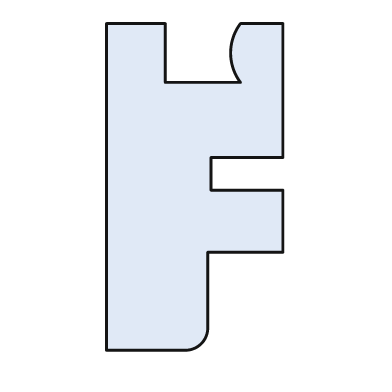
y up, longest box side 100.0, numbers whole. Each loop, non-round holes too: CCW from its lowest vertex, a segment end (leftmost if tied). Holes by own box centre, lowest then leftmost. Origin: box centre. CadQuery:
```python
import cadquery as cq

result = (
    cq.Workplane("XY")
    .moveTo(-27.0, -50.0)
    .lineTo(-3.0, -50.0)
    .threePointArc((2.0, -48.0), (4.0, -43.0))
    .lineTo(4.0, -20.0)
    .lineTo(27.0, -20.0)
    .lineTo(27.0, -1.0)
    .lineTo(5.0, -1.0)
    .lineTo(5.0, 9.0)
    .lineTo(27.0, 9.0)
    .lineTo(27.0, 50.0)
    .lineTo(14.0, 50.0)
    .threePointArc((11.0, 41.0), (14.0, 32.0))
    .lineTo(-9.0, 32.0)
    .lineTo(-9.0, 50.0)
    .lineTo(-27.0, 50.0)
    .close()
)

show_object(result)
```